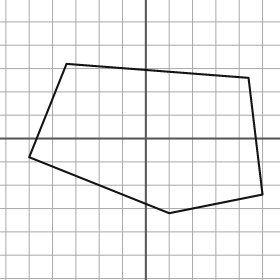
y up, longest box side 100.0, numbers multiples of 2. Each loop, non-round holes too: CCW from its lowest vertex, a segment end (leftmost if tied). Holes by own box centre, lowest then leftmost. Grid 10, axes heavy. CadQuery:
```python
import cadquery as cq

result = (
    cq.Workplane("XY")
    .moveTo(10.0, -32.0)
    .lineTo(50.0, -24.0)
    .lineTo(44.0, 26.0)
    .lineTo(-34.0, 32.0)
    .lineTo(-50.0, -8.0)
    .close()
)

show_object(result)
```